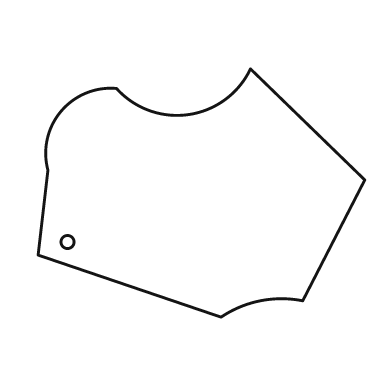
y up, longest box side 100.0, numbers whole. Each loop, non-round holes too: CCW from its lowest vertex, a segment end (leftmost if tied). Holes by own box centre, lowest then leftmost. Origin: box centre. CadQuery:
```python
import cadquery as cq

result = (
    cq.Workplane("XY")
    .moveTo(6.0, -38.0)
    .threePointArc((18.0, -33.0), (31.0, -33.0))
    .lineTo(50.0, 4.0)
    .lineTo(15.0, 38.0)
    .threePointArc((-4.0, 24.0), (-26.0, 32.0))
    .threePointArc((-43.0, 25.0), (-47.0, 7.0))
    .lineTo(-50.0, -19.0)
    .close()
    .moveTo(-41.0, -15.0)
    .circle(2.0)
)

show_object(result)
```